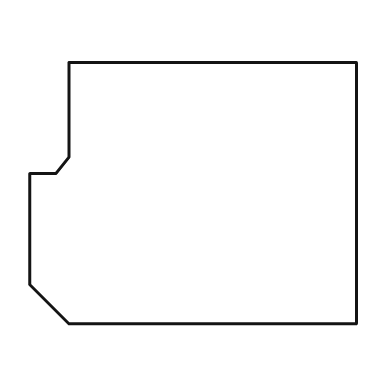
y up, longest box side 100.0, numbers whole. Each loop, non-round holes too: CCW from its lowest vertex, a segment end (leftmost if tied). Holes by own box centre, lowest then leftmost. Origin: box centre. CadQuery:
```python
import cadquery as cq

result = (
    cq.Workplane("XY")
    .moveTo(-38.0, -40.0)
    .lineTo(50.0, -40.0)
    .lineTo(50.0, 40.0)
    .lineTo(-38.0, 40.0)
    .lineTo(-38.0, 11.0)
    .lineTo(-42.0, 6.0)
    .lineTo(-50.0, 6.0)
    .lineTo(-50.0, -28.0)
    .close()
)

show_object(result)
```